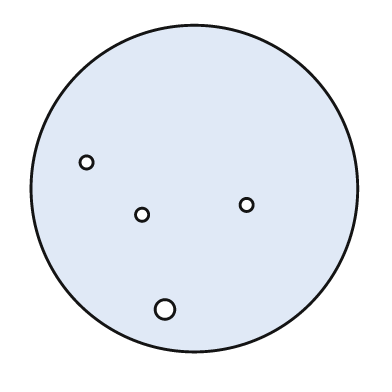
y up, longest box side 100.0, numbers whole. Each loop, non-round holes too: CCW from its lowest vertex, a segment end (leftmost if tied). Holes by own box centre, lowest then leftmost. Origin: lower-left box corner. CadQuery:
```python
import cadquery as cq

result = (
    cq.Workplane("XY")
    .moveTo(50.0, 50.0)
    .circle(50.0)
    .moveTo(41.0, 13.0)
    .circle(3.0)
    .moveTo(34.0, 42.0)
    .circle(2.0)
    .moveTo(66.0, 45.0)
    .circle(2.0)
    .moveTo(17.0, 58.0)
    .circle(2.0)
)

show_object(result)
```